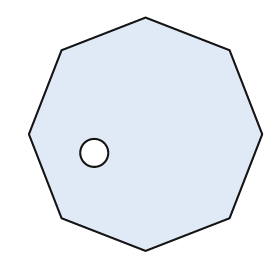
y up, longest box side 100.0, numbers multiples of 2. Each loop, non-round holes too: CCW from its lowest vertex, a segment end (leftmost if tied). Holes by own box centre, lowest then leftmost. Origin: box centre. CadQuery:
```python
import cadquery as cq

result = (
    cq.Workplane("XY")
    .moveTo(0.0, -50.0)
    .lineTo(36.0, -36.0)
    .lineTo(50.0, 0.0)
    .lineTo(36.0, 36.0)
    .lineTo(0.0, 50.0)
    .lineTo(-36.0, 36.0)
    .lineTo(-50.0, 0.0)
    .lineTo(-36.0, -36.0)
    .close()
    .moveTo(-22.0, -8.0)
    .circle(6.0)
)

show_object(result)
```